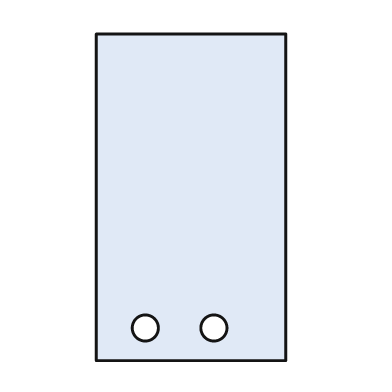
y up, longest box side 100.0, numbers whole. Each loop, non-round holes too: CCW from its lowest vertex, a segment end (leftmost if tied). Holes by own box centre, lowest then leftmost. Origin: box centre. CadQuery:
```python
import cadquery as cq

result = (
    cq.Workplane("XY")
    .moveTo(-29.0, -50.0)
    .lineTo(29.0, -50.0)
    .lineTo(29.0, 50.0)
    .lineTo(-29.0, 50.0)
    .close()
    .moveTo(-14.0, -40.0)
    .circle(4.0)
    .moveTo(7.0, -40.0)
    .circle(4.0)
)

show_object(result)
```